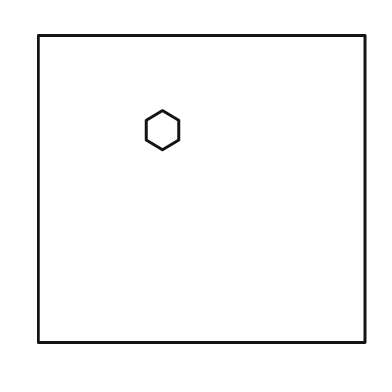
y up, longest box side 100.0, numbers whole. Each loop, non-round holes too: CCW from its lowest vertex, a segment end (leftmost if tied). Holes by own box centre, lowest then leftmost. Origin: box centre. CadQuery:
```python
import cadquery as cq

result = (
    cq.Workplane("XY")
    .moveTo(-50.0, -47.0)
    .lineTo(50.0, -47.0)
    .lineTo(50.0, 47.0)
    .lineTo(-50.0, 47.0)
    .close()
    .moveTo(-12.0, 12.0)
    .lineTo(-7.0, 15.0)
    .lineTo(-7.0, 21.0)
    .lineTo(-12.0, 24.0)
    .lineTo(-17.0, 21.0)
    .lineTo(-17.0, 15.0)
    .close()
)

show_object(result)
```